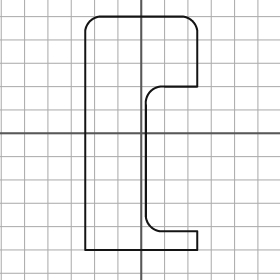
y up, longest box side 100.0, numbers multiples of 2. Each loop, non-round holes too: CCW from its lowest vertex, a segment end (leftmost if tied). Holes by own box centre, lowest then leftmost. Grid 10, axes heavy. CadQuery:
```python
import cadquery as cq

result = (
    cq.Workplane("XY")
    .moveTo(-24.0, -50.0)
    .lineTo(24.0, -50.0)
    .lineTo(24.0, -42.0)
    .lineTo(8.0, -42.0)
    .threePointArc((4.0, -40.0), (2.0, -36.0))
    .lineTo(2.0, 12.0)
    .threePointArc((4.0, 18.0), (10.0, 20.0))
    .lineTo(24.0, 20.0)
    .lineTo(24.0, 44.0)
    .threePointArc((22.0, 48.0), (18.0, 50.0))
    .lineTo(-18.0, 50.0)
    .threePointArc((-22.0, 48.0), (-24.0, 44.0))
    .close()
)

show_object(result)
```